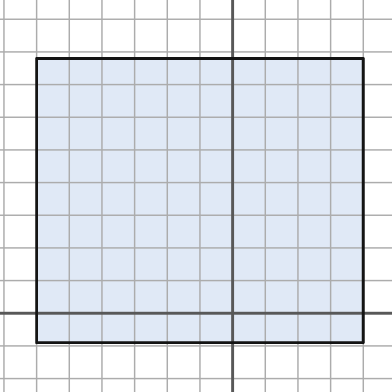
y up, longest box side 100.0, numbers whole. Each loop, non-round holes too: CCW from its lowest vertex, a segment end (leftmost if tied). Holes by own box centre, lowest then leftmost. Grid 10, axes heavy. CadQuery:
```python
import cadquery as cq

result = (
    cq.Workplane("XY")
    .moveTo(-60.0, -9.0)
    .lineTo(40.0, -9.0)
    .lineTo(40.0, 78.0)
    .lineTo(-60.0, 78.0)
    .close()
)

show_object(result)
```